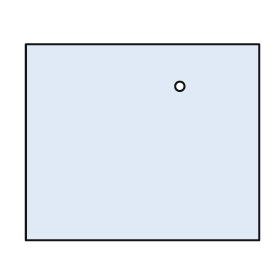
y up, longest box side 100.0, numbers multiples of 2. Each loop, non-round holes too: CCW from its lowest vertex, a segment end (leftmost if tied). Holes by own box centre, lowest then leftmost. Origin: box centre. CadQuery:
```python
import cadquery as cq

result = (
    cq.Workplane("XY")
    .moveTo(-50.0, -42.0)
    .lineTo(50.0, -42.0)
    .lineTo(50.0, 42.0)
    .lineTo(-50.0, 42.0)
    .close()
    .moveTo(16.0, 24.0)
    .circle(2.0)
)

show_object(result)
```